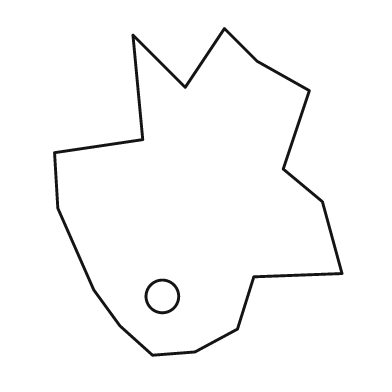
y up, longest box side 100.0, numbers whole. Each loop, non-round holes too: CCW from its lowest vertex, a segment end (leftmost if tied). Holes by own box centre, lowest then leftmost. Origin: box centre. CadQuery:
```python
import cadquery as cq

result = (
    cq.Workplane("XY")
    .moveTo(-14.0, -50.0)
    .lineTo(-1.0, -49.0)
    .lineTo(12.0, -42.0)
    .lineTo(17.0, -26.0)
    .lineTo(44.0, -25.0)
    .lineTo(38.0, -3.0)
    .lineTo(26.0, 7.0)
    .lineTo(34.0, 31.0)
    .lineTo(18.0, 40.0)
    .lineTo(8.0, 50.0)
    .lineTo(-4.0, 32.0)
    .lineTo(-20.0, 48.0)
    .lineTo(-17.0, 16.0)
    .lineTo(-44.0, 12.0)
    .lineTo(-43.0, -5.0)
    .lineTo(-32.0, -30.0)
    .lineTo(-24.0, -41.0)
    .close()
    .moveTo(-11.0, -32.0)
    .circle(5.0)
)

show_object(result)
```